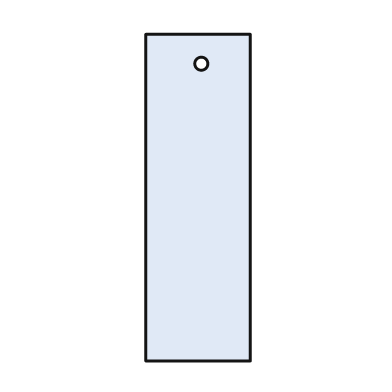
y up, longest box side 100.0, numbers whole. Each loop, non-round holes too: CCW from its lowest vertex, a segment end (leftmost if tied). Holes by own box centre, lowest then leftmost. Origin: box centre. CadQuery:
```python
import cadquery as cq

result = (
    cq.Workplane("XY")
    .moveTo(-16.0, -50.0)
    .lineTo(16.0, -50.0)
    .lineTo(16.0, 50.0)
    .lineTo(-16.0, 50.0)
    .close()
    .moveTo(1.0, 41.0)
    .circle(2.0)
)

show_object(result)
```